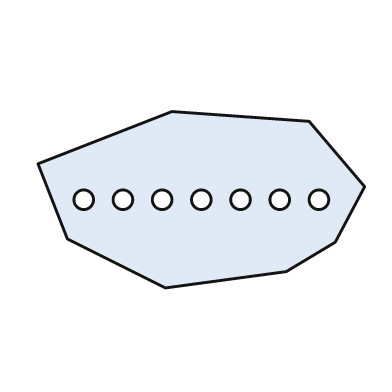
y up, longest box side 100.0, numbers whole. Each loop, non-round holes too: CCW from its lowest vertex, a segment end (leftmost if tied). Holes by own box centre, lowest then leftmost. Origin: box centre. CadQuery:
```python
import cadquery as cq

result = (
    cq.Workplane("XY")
    .moveTo(-11.0, -27.0)
    .lineTo(26.0, -22.0)
    .lineTo(41.0, -13.0)
    .lineTo(50.0, 4.0)
    .lineTo(33.0, 24.0)
    .lineTo(-9.0, 27.0)
    .lineTo(-50.0, 11.0)
    .lineTo(-41.0, -12.0)
    .close()
    .moveTo(-36.0, 0.0)
    .circle(3.0)
    .moveTo(-24.0, 0.0)
    .circle(3.0)
    .moveTo(-12.0, 0.0)
    .circle(3.0)
    .moveTo(0.0, 0.0)
    .circle(3.0)
    .moveTo(12.0, 0.0)
    .circle(3.0)
    .moveTo(24.0, 0.0)
    .circle(3.0)
    .moveTo(36.0, 0.0)
    .circle(3.0)
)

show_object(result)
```